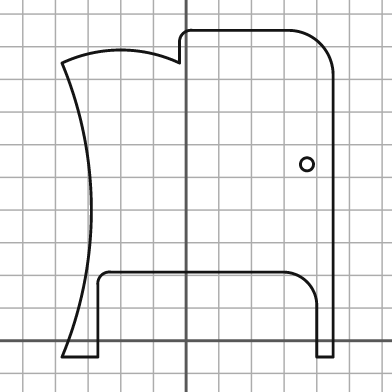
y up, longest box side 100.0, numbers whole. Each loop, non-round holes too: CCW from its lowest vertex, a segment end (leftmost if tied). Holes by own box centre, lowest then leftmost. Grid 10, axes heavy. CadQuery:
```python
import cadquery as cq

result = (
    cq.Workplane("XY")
    .moveTo(-38.0, -5.0)
    .lineTo(-27.0, -5.0)
    .lineTo(-27.0, 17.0)
    .threePointArc((-26.0, 20.0), (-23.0, 21.0))
    .lineTo(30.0, 21.0)
    .threePointArc((37.0, 18.0), (40.0, 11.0))
    .lineTo(40.0, -5.0)
    .lineTo(45.0, -5.0)
    .lineTo(45.0, 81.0)
    .threePointArc((41.0, 91.0), (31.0, 95.0))
    .lineTo(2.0, 95.0)
    .threePointArc((-1.0, 94.0), (-2.0, 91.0))
    .lineTo(-2.0, 85.0)
    .threePointArc((-20.0, 89.0), (-38.0, 85.0))
    .threePointArc((-29.0, 40.0), (-38.0, -5.0))
    .close()
    .moveTo(37.0, 54.0)
    .circle(2.0)
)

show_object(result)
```